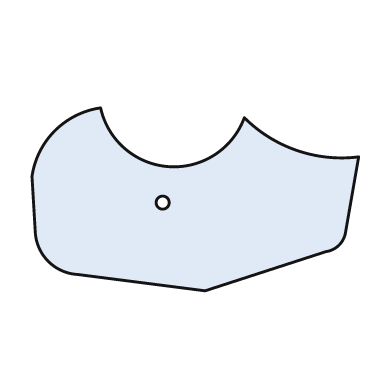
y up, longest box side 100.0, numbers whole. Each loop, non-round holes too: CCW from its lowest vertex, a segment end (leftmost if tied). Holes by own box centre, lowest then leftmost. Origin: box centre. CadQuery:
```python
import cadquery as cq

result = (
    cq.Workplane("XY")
    .moveTo(3.0, -28.0)
    .lineTo(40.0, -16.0)
    .threePointArc((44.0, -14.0), (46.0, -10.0))
    .lineTo(50.0, 13.0)
    .threePointArc((31.0, 15.0), (15.0, 25.0))
    .threePointArc((-8.0, 10.0), (-29.0, 28.0))
    .threePointArc((-43.0, 21.0), (-50.0, 7.0))
    .lineTo(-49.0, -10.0)
    .threePointArc((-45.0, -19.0), (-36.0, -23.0))
    .close()
    .moveTo(-10.0, -1.0)
    .circle(2.0)
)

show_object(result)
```